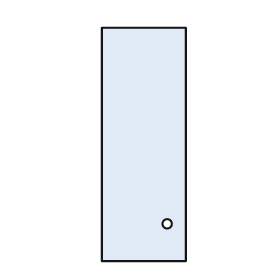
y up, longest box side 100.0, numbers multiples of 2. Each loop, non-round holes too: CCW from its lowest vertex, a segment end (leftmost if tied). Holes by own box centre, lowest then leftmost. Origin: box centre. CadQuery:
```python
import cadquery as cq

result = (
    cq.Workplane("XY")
    .moveTo(-18.0, -50.0)
    .lineTo(18.0, -50.0)
    .lineTo(18.0, 50.0)
    .lineTo(-18.0, 50.0)
    .close()
    .moveTo(10.0, -34.0)
    .circle(2.0)
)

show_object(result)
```